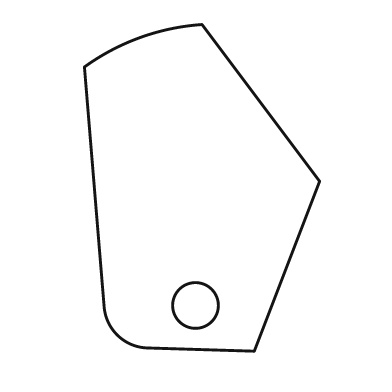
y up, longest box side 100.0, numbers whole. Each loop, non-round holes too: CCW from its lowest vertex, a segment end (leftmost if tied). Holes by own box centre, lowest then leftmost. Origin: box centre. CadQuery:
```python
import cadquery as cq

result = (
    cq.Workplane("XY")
    .moveTo(16.0, -50.0)
    .lineTo(36.0, 2.0)
    .lineTo(0.0, 50.0)
    .threePointArc((-19.0, 46.0), (-36.0, 37.0))
    .lineTo(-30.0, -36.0)
    .threePointArc((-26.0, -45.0), (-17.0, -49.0))
    .close()
    .moveTo(-2.0, -36.0)
    .circle(7.0)
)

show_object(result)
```